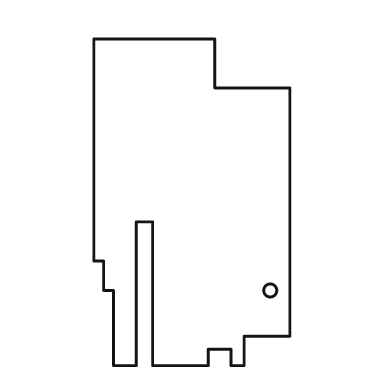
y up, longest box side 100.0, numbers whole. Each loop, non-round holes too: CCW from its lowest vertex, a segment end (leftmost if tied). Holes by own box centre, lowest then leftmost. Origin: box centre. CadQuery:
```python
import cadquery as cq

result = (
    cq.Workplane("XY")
    .moveTo(-24.0, -50.0)
    .lineTo(-17.0, -50.0)
    .lineTo(-17.0, -6.0)
    .lineTo(-12.0, -6.0)
    .lineTo(-12.0, -50.0)
    .lineTo(5.0, -50.0)
    .lineTo(5.0, -45.0)
    .lineTo(12.0, -45.0)
    .lineTo(12.0, -50.0)
    .lineTo(16.0, -50.0)
    .lineTo(16.0, -41.0)
    .lineTo(30.0, -41.0)
    .lineTo(30.0, 35.0)
    .lineTo(7.0, 35.0)
    .lineTo(7.0, 50.0)
    .lineTo(-30.0, 50.0)
    .lineTo(-30.0, -18.0)
    .lineTo(-27.0, -18.0)
    .lineTo(-27.0, -27.0)
    .lineTo(-24.0, -27.0)
    .close()
    .moveTo(24.0, -27.0)
    .circle(2.0)
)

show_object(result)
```